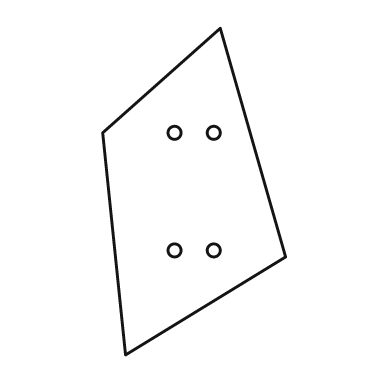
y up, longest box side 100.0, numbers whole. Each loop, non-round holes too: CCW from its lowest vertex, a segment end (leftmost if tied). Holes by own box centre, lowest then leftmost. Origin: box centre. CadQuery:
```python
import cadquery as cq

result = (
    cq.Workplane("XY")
    .moveTo(-21.0, -50.0)
    .lineTo(28.0, -20.0)
    .lineTo(8.0, 50.0)
    .lineTo(-28.0, 18.0)
    .close()
    .moveTo(-6.0, -18.0)
    .circle(2.0)
    .moveTo(6.0, -18.0)
    .circle(2.0)
    .moveTo(-6.0, 18.0)
    .circle(2.0)
    .moveTo(6.0, 18.0)
    .circle(2.0)
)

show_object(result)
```